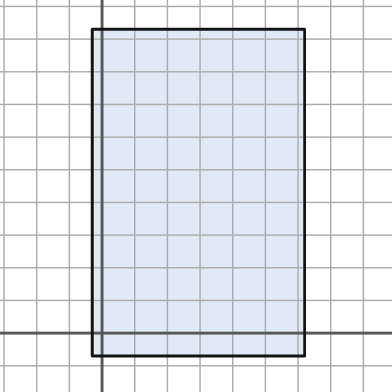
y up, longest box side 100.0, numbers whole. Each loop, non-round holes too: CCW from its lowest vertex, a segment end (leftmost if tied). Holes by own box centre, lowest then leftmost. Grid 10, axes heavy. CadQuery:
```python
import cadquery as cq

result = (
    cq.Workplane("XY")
    .moveTo(-3.0, -7.0)
    .lineTo(62.0, -7.0)
    .lineTo(62.0, 93.0)
    .lineTo(-3.0, 93.0)
    .close()
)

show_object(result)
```